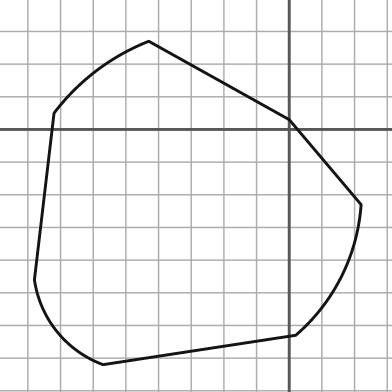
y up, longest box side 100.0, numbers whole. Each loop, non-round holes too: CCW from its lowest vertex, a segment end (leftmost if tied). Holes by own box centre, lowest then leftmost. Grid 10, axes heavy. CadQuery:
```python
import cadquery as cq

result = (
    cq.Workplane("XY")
    .moveTo(-57.0, -72.0)
    .lineTo(2.0, -63.0)
    .threePointArc((16.0, -45.0), (22.0, -23.0))
    .lineTo(0.0, 3.0)
    .lineTo(-43.0, 27.0)
    .threePointArc((-59.0, 18.0), (-72.0, 5.0))
    .lineTo(-78.0, -46.0)
    .threePointArc((-71.0, -62.0), (-57.0, -72.0))
    .close()
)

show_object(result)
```